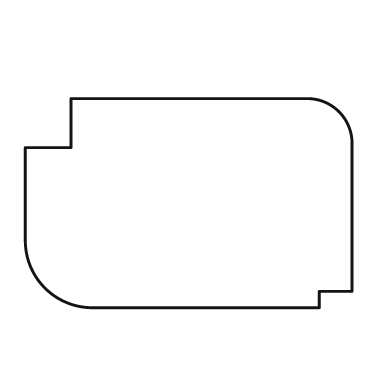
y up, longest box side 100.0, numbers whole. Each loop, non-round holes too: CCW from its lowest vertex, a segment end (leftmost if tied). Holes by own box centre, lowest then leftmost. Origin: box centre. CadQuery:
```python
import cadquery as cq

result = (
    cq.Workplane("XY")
    .moveTo(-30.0, -32.0)
    .lineTo(40.0, -32.0)
    .lineTo(40.0, -27.0)
    .lineTo(50.0, -27.0)
    .lineTo(50.0, 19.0)
    .threePointArc((46.0, 28.0), (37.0, 32.0))
    .lineTo(-36.0, 32.0)
    .lineTo(-36.0, 17.0)
    .lineTo(-50.0, 17.0)
    .lineTo(-50.0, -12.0)
    .threePointArc((-44.0, -26.0), (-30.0, -32.0))
    .close()
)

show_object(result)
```